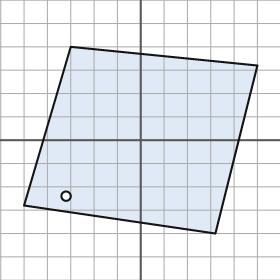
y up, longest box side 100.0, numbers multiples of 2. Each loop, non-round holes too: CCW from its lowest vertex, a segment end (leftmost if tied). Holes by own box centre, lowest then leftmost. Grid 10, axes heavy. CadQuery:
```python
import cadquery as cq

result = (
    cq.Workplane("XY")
    .moveTo(32.0, -40.0)
    .lineTo(50.0, 32.0)
    .lineTo(-30.0, 40.0)
    .lineTo(-50.0, -28.0)
    .close()
    .moveTo(-32.0, -24.0)
    .circle(2.0)
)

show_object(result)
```